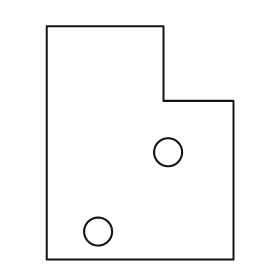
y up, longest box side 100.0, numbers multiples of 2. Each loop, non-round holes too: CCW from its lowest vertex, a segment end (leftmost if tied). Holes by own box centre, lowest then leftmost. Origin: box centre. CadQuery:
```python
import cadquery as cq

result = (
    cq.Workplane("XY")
    .moveTo(-40.0, -50.0)
    .lineTo(40.0, -50.0)
    .lineTo(40.0, 18.0)
    .lineTo(10.0, 18.0)
    .lineTo(10.0, 50.0)
    .lineTo(-40.0, 50.0)
    .close()
    .moveTo(-18.0, -38.0)
    .circle(6.0)
    .moveTo(12.0, -4.0)
    .circle(6.0)
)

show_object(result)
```